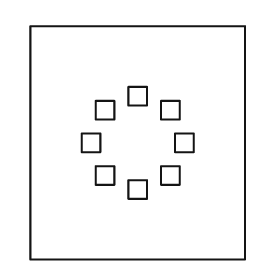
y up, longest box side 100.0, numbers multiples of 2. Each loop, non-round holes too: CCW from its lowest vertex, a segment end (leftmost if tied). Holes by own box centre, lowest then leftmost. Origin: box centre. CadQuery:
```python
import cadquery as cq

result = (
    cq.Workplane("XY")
    .moveTo(-46.0, -50.0)
    .lineTo(46.0, -50.0)
    .lineTo(46.0, 50.0)
    .lineTo(-46.0, 50.0)
    .close()
    .moveTo(-4.0, -24.0)
    .lineTo(4.0, -24.0)
    .lineTo(4.0, -16.0)
    .lineTo(-4.0, -16.0)
    .close()
    .moveTo(-18.0, -18.0)
    .lineTo(-10.0, -18.0)
    .lineTo(-10.0, -10.0)
    .lineTo(-18.0, -10.0)
    .close()
    .moveTo(10.0, -18.0)
    .lineTo(18.0, -18.0)
    .lineTo(18.0, -10.0)
    .lineTo(10.0, -10.0)
    .close()
    .moveTo(-24.0, -4.0)
    .lineTo(-16.0, -4.0)
    .lineTo(-16.0, 4.0)
    .lineTo(-24.0, 4.0)
    .close()
    .moveTo(16.0, -4.0)
    .lineTo(24.0, -4.0)
    .lineTo(24.0, 4.0)
    .lineTo(16.0, 4.0)
    .close()
    .moveTo(-18.0, 10.0)
    .lineTo(-10.0, 10.0)
    .lineTo(-10.0, 18.0)
    .lineTo(-18.0, 18.0)
    .close()
    .moveTo(10.0, 10.0)
    .lineTo(18.0, 10.0)
    .lineTo(18.0, 18.0)
    .lineTo(10.0, 18.0)
    .close()
    .moveTo(-4.0, 16.0)
    .lineTo(4.0, 16.0)
    .lineTo(4.0, 24.0)
    .lineTo(-4.0, 24.0)
    .close()
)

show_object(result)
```